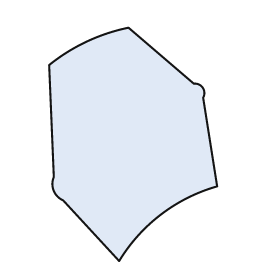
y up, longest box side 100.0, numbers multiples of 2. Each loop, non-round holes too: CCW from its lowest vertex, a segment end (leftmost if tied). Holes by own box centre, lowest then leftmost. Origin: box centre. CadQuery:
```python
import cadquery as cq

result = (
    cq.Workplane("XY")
    .moveTo(-6.0, -50.0)
    .threePointArc((12.0, -30.0), (36.0, -18.0))
    .lineTo(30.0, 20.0)
    .threePointArc((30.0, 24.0), (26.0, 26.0))
    .lineTo(-2.0, 50.0)
    .threePointArc((-20.0, 44.0), (-36.0, 34.0))
    .lineTo(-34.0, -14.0)
    .threePointArc((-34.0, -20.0), (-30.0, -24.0))
    .close()
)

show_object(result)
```